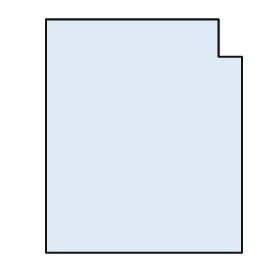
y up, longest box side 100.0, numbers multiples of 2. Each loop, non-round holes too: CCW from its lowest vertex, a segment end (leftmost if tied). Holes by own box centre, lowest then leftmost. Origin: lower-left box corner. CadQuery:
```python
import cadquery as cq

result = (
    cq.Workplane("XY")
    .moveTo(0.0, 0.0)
    .lineTo(84.0, 0.0)
    .lineTo(84.0, 84.0)
    .lineTo(74.0, 84.0)
    .lineTo(74.0, 100.0)
    .lineTo(0.0, 100.0)
    .close()
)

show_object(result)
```